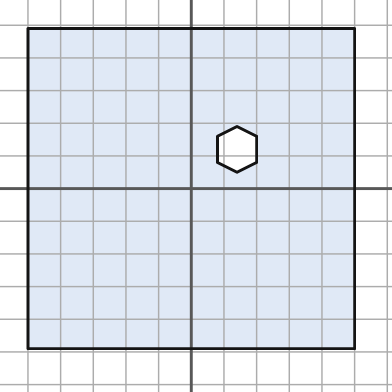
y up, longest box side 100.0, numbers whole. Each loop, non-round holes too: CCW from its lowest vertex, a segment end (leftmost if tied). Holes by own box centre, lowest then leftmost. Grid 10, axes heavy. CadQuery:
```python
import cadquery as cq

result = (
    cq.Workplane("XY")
    .moveTo(-50.0, -49.0)
    .lineTo(50.0, -49.0)
    .lineTo(50.0, 49.0)
    .lineTo(-50.0, 49.0)
    .close()
    .moveTo(14.0, 5.0)
    .lineTo(20.0, 8.0)
    .lineTo(20.0, 16.0)
    .lineTo(14.0, 19.0)
    .lineTo(8.0, 16.0)
    .lineTo(8.0, 8.0)
    .close()
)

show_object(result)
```